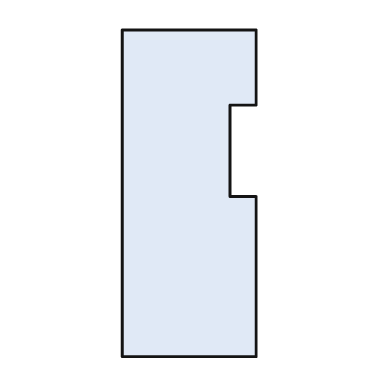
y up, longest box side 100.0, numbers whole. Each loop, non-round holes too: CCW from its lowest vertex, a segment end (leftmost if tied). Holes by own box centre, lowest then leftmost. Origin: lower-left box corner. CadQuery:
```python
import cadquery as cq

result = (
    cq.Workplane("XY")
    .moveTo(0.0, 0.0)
    .lineTo(41.0, 0.0)
    .lineTo(41.0, 49.0)
    .lineTo(33.0, 49.0)
    .lineTo(33.0, 77.0)
    .lineTo(41.0, 77.0)
    .lineTo(41.0, 100.0)
    .lineTo(0.0, 100.0)
    .close()
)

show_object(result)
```